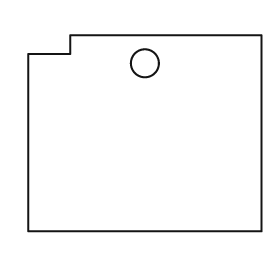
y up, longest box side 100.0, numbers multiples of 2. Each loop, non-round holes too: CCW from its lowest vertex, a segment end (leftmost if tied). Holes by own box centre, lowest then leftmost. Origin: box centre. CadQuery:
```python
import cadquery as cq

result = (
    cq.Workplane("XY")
    .moveTo(-50.0, -42.0)
    .lineTo(50.0, -42.0)
    .lineTo(50.0, 42.0)
    .lineTo(-32.0, 42.0)
    .lineTo(-32.0, 34.0)
    .lineTo(-50.0, 34.0)
    .close()
    .moveTo(0.0, 30.0)
    .circle(6.0)
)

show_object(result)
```